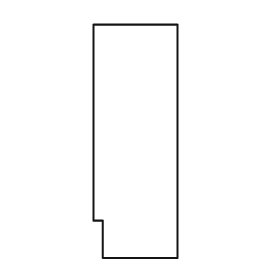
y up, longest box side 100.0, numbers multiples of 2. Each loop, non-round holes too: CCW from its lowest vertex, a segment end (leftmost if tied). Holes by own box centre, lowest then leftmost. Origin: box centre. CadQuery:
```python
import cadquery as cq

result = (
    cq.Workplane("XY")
    .moveTo(-14.0, -50.0)
    .lineTo(18.0, -50.0)
    .lineTo(18.0, 50.0)
    .lineTo(-18.0, 50.0)
    .lineTo(-18.0, -34.0)
    .lineTo(-14.0, -34.0)
    .close()
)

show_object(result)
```